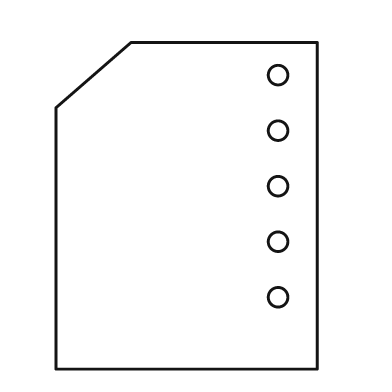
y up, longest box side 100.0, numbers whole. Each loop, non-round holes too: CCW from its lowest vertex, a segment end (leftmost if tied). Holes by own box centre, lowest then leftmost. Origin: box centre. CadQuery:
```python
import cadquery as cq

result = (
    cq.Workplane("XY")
    .moveTo(-40.0, -50.0)
    .lineTo(40.0, -50.0)
    .lineTo(40.0, 50.0)
    .lineTo(-17.0, 50.0)
    .lineTo(-40.0, 30.0)
    .close()
    .moveTo(28.0, -28.0)
    .circle(3.0)
    .moveTo(28.0, -11.0)
    .circle(3.0)
    .moveTo(28.0, 6.0)
    .circle(3.0)
    .moveTo(28.0, 23.0)
    .circle(3.0)
    .moveTo(28.0, 40.0)
    .circle(3.0)
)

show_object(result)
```